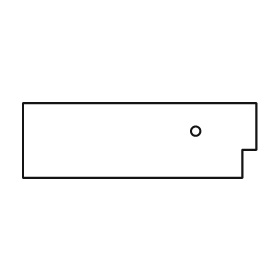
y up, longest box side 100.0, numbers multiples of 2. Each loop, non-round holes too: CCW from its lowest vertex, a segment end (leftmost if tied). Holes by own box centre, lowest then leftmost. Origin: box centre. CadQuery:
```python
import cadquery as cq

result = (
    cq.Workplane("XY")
    .moveTo(-50.0, -16.0)
    .lineTo(44.0, -16.0)
    .lineTo(44.0, -4.0)
    .lineTo(50.0, -4.0)
    .lineTo(50.0, 16.0)
    .lineTo(-50.0, 16.0)
    .close()
    .moveTo(24.0, 4.0)
    .circle(2.0)
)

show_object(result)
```